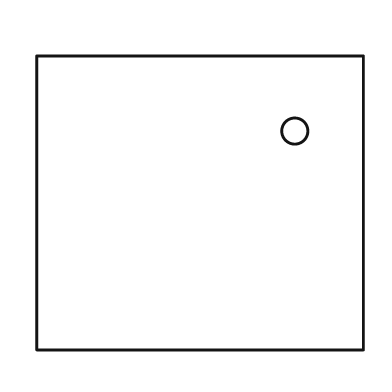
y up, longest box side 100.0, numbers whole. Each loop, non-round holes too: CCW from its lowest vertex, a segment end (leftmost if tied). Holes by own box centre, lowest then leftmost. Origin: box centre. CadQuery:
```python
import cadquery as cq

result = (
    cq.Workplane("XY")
    .moveTo(-50.0, -45.0)
    .lineTo(50.0, -45.0)
    .lineTo(50.0, 45.0)
    .lineTo(-50.0, 45.0)
    .close()
    .moveTo(29.0, 22.0)
    .circle(4.0)
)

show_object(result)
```